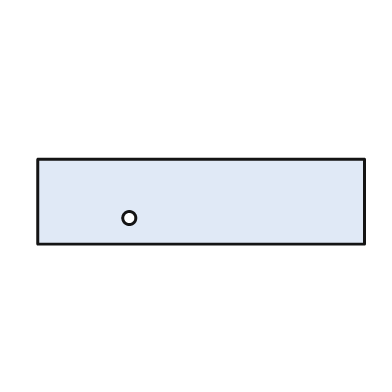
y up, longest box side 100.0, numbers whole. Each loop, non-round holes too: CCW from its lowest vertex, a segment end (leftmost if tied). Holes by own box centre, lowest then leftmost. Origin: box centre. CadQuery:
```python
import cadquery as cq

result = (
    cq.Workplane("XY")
    .moveTo(-50.0, -13.0)
    .lineTo(50.0, -13.0)
    .lineTo(50.0, 13.0)
    .lineTo(-50.0, 13.0)
    .close()
    .moveTo(-22.0, -5.0)
    .circle(2.0)
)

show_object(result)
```